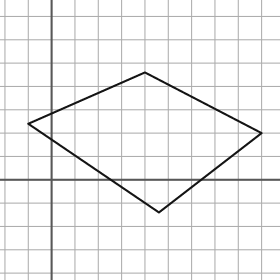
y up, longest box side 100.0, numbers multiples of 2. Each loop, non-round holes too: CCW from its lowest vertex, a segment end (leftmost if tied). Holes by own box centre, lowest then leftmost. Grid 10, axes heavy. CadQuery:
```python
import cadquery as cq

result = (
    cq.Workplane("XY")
    .moveTo(46.0, -14.0)
    .lineTo(90.0, 20.0)
    .lineTo(40.0, 46.0)
    .lineTo(-10.0, 24.0)
    .close()
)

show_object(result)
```